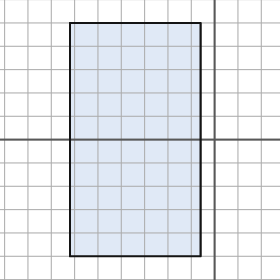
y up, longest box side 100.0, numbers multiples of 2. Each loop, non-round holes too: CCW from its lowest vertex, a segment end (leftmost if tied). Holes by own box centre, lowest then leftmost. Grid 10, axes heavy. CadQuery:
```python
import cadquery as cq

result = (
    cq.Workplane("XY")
    .moveTo(-62.0, -50.0)
    .lineTo(-6.0, -50.0)
    .lineTo(-6.0, 50.0)
    .lineTo(-62.0, 50.0)
    .close()
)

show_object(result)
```